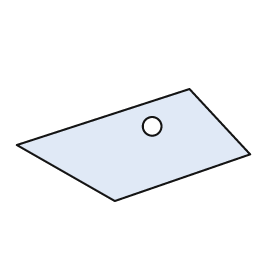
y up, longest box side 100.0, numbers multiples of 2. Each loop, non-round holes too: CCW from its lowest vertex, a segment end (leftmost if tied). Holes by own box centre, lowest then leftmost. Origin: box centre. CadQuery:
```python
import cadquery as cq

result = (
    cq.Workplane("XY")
    .moveTo(-8.0, -24.0)
    .lineTo(50.0, -4.0)
    .lineTo(24.0, 24.0)
    .lineTo(-50.0, 0.0)
    .close()
    .moveTo(8.0, 8.0)
    .circle(4.0)
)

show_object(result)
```